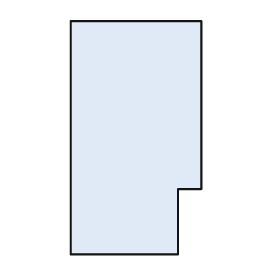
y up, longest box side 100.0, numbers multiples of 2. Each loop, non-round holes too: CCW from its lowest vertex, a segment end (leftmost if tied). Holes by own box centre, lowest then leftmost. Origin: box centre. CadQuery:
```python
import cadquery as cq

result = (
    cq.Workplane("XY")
    .moveTo(-28.0, -50.0)
    .lineTo(18.0, -50.0)
    .lineTo(18.0, -22.0)
    .lineTo(28.0, -22.0)
    .lineTo(28.0, 50.0)
    .lineTo(-28.0, 50.0)
    .close()
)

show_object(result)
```